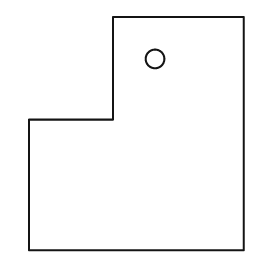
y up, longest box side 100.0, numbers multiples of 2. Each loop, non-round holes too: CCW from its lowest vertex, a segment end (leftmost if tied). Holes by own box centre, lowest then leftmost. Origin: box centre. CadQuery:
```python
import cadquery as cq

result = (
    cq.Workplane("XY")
    .moveTo(-46.0, -50.0)
    .lineTo(46.0, -50.0)
    .lineTo(46.0, 50.0)
    .lineTo(-10.0, 50.0)
    .lineTo(-10.0, 6.0)
    .lineTo(-46.0, 6.0)
    .close()
    .moveTo(8.0, 32.0)
    .circle(4.0)
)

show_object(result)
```